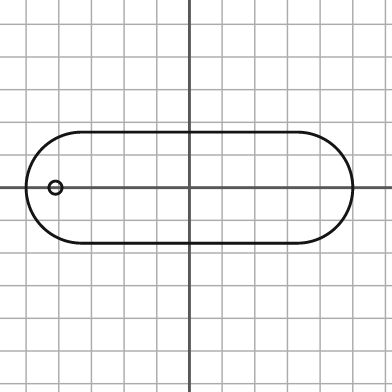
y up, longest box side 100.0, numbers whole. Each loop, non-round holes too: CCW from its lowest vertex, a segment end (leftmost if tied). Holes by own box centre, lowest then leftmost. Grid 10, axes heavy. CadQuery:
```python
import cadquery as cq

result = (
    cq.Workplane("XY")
    .moveTo(-33.0, -17.0)
    .lineTo(33.0, -17.0)
    .threePointArc((50.0, 0.0), (33.0, 17.0))
    .lineTo(-33.0, 17.0)
    .threePointArc((-50.0, 0.0), (-33.0, -17.0))
    .close()
    .moveTo(-41.0, 0.0)
    .circle(2.0)
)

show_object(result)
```